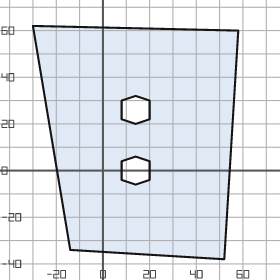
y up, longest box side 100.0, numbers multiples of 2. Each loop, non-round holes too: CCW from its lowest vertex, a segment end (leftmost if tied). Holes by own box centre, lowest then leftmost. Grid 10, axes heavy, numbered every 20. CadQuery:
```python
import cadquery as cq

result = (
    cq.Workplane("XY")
    .moveTo(52.0, -38.0)
    .lineTo(58.0, 60.0)
    .lineTo(-30.0, 62.0)
    .lineTo(-14.0, -34.0)
    .close()
    .moveTo(14.0, -6.0)
    .lineTo(20.0, -4.0)
    .lineTo(20.0, 4.0)
    .lineTo(14.0, 6.0)
    .lineTo(8.0, 4.0)
    .lineTo(8.0, -4.0)
    .close()
    .moveTo(14.0, 20.0)
    .lineTo(20.0, 22.0)
    .lineTo(20.0, 30.0)
    .lineTo(14.0, 32.0)
    .lineTo(8.0, 30.0)
    .lineTo(8.0, 22.0)
    .close()
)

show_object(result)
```